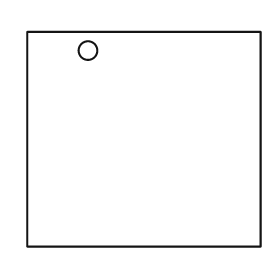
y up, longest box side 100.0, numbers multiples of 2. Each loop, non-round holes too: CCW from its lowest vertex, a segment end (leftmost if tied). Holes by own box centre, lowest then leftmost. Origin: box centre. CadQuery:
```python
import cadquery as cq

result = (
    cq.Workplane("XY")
    .moveTo(-50.0, -46.0)
    .lineTo(50.0, -46.0)
    .lineTo(50.0, 46.0)
    .lineTo(-50.0, 46.0)
    .close()
    .moveTo(-24.0, 38.0)
    .circle(4.0)
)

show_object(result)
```